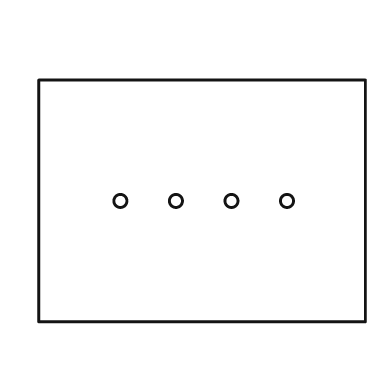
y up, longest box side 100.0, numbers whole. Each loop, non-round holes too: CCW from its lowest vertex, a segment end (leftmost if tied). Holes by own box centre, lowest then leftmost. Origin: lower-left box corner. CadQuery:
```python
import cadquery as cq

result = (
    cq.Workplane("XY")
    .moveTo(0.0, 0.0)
    .lineTo(100.0, 0.0)
    .lineTo(100.0, 74.0)
    .lineTo(0.0, 74.0)
    .close()
    .moveTo(25.0, 37.0)
    .circle(2.0)
    .moveTo(42.0, 37.0)
    .circle(2.0)
    .moveTo(59.0, 37.0)
    .circle(2.0)
    .moveTo(76.0, 37.0)
    .circle(2.0)
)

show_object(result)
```